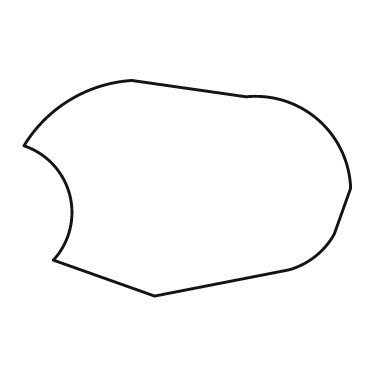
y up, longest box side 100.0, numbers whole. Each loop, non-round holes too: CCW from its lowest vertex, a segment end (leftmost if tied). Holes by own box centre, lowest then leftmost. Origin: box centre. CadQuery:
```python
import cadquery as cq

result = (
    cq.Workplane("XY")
    .moveTo(-10.0, -33.0)
    .lineTo(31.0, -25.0)
    .threePointArc((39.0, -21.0), (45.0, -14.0))
    .lineTo(50.0, 0.0)
    .threePointArc((40.0, 21.0), (18.0, 28.0))
    .lineTo(-17.0, 33.0)
    .threePointArc((-36.0, 27.0), (-50.0, 13.0))
    .threePointArc((-36.0, -2.0), (-41.0, -22.0))
    .close()
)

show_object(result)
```